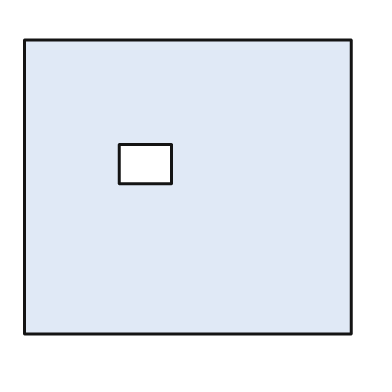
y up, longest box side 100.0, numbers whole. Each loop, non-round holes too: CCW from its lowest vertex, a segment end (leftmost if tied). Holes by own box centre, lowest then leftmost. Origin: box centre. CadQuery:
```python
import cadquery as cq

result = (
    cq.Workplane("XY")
    .moveTo(-50.0, -45.0)
    .lineTo(50.0, -45.0)
    .lineTo(50.0, 45.0)
    .lineTo(-50.0, 45.0)
    .close()
    .moveTo(-21.0, 1.0)
    .lineTo(-5.0, 1.0)
    .lineTo(-5.0, 13.0)
    .lineTo(-21.0, 13.0)
    .close()
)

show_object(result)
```